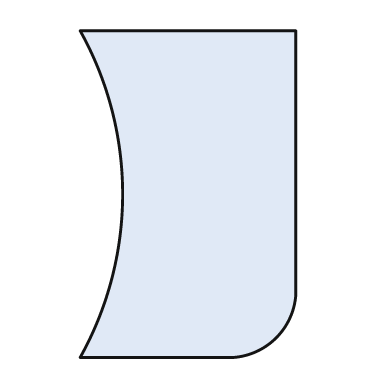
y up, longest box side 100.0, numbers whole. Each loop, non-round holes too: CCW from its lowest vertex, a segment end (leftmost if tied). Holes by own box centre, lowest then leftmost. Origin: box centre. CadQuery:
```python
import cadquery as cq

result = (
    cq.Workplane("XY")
    .moveTo(-33.0, -50.0)
    .lineTo(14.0, -50.0)
    .threePointArc((27.0, -44.0), (33.0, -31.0))
    .lineTo(33.0, 50.0)
    .lineTo(-33.0, 50.0)
    .threePointArc((-20.0, 0.0), (-33.0, -50.0))
    .close()
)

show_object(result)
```